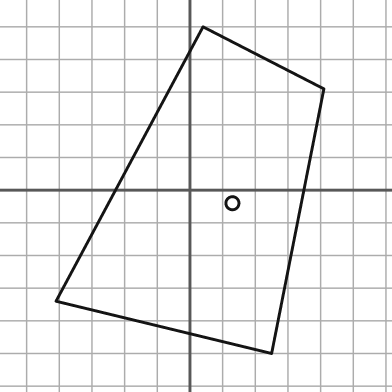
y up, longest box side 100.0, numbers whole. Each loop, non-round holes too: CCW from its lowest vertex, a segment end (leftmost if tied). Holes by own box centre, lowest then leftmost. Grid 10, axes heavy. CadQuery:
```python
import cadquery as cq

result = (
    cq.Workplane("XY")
    .moveTo(25.0, -50.0)
    .lineTo(41.0, 31.0)
    .lineTo(4.0, 50.0)
    .lineTo(-41.0, -34.0)
    .close()
    .moveTo(13.0, -4.0)
    .circle(2.0)
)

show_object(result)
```